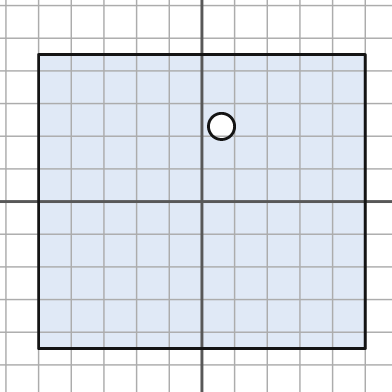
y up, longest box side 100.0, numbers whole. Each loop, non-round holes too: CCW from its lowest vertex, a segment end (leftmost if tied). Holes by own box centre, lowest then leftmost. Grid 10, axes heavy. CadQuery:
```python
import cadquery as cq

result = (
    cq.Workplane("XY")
    .moveTo(-50.0, -45.0)
    .lineTo(50.0, -45.0)
    .lineTo(50.0, 45.0)
    .lineTo(-50.0, 45.0)
    .close()
    .moveTo(6.0, 23.0)
    .circle(4.0)
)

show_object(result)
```